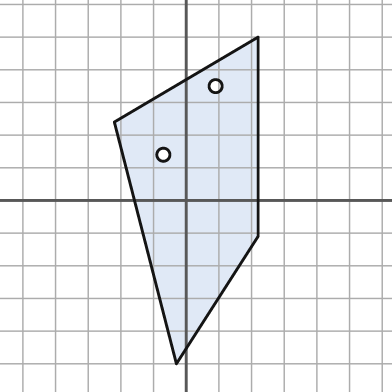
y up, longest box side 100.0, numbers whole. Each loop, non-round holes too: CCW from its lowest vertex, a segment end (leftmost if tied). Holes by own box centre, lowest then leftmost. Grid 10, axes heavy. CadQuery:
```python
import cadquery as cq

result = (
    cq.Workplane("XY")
    .moveTo(-3.0, -50.0)
    .lineTo(22.0, -11.0)
    .lineTo(22.0, 50.0)
    .lineTo(-22.0, 24.0)
    .close()
    .moveTo(-7.0, 14.0)
    .circle(2.0)
    .moveTo(9.0, 35.0)
    .circle(2.0)
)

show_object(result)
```